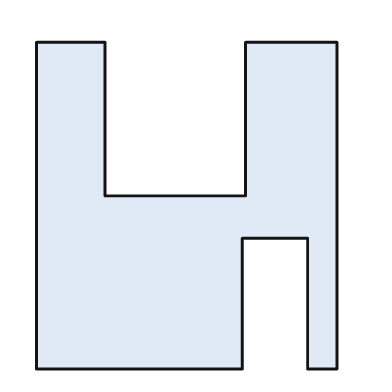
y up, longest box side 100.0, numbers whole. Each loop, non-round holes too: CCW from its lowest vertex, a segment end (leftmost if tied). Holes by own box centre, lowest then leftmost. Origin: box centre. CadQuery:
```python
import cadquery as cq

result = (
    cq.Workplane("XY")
    .moveTo(-46.0, -50.0)
    .lineTo(17.0, -50.0)
    .lineTo(17.0, -10.0)
    .lineTo(37.0, -10.0)
    .lineTo(37.0, -50.0)
    .lineTo(46.0, -50.0)
    .lineTo(46.0, 50.0)
    .lineTo(18.0, 50.0)
    .lineTo(18.0, 3.0)
    .lineTo(-25.0, 3.0)
    .lineTo(-25.0, 50.0)
    .lineTo(-46.0, 50.0)
    .close()
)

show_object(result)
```